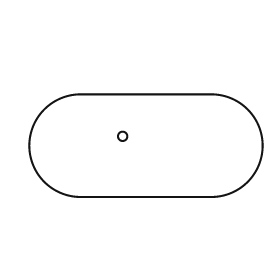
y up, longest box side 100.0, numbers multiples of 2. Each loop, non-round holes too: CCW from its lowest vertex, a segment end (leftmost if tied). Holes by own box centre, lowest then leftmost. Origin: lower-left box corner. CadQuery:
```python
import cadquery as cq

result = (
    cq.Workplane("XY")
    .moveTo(22.0, 0.0)
    .lineTo(78.0, 0.0)
    .threePointArc((100.0, 22.0), (78.0, 44.0))
    .lineTo(22.0, 44.0)
    .threePointArc((0.0, 22.0), (22.0, 0.0))
    .close()
    .moveTo(40.0, 26.0)
    .circle(2.0)
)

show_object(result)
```